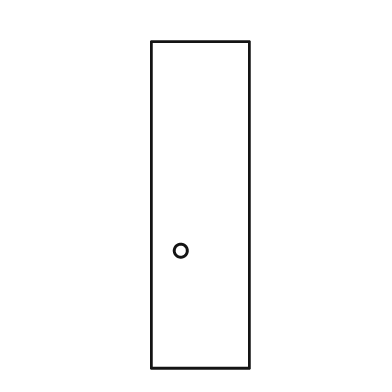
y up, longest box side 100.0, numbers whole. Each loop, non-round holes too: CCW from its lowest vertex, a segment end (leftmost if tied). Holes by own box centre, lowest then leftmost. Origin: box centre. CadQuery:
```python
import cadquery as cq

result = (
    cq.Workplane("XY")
    .moveTo(-15.0, -50.0)
    .lineTo(15.0, -50.0)
    .lineTo(15.0, 50.0)
    .lineTo(-15.0, 50.0)
    .close()
    .moveTo(-6.0, -14.0)
    .circle(2.0)
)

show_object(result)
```